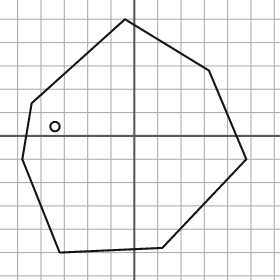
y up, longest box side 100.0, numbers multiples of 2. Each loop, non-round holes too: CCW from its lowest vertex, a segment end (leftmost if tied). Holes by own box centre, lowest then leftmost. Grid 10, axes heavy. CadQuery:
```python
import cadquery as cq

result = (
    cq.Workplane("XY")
    .moveTo(-32.0, -50.0)
    .lineTo(12.0, -48.0)
    .lineTo(48.0, -10.0)
    .lineTo(32.0, 28.0)
    .lineTo(-4.0, 50.0)
    .lineTo(-44.0, 14.0)
    .lineTo(-48.0, -10.0)
    .close()
    .moveTo(-34.0, 4.0)
    .circle(2.0)
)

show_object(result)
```